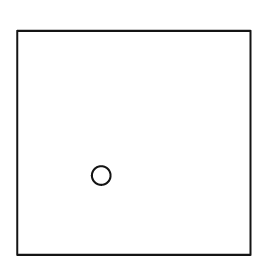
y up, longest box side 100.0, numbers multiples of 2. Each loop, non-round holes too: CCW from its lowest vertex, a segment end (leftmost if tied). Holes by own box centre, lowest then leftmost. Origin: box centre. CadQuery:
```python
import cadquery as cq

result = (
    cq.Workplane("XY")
    .moveTo(-50.0, -48.0)
    .lineTo(50.0, -48.0)
    .lineTo(50.0, 48.0)
    .lineTo(-50.0, 48.0)
    .close()
    .moveTo(-14.0, -14.0)
    .circle(4.0)
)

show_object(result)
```